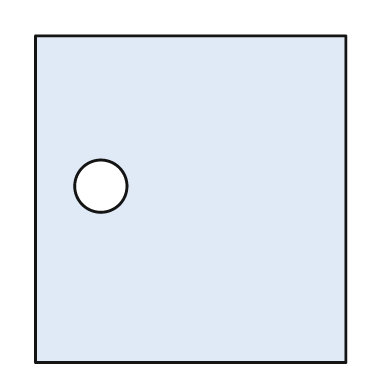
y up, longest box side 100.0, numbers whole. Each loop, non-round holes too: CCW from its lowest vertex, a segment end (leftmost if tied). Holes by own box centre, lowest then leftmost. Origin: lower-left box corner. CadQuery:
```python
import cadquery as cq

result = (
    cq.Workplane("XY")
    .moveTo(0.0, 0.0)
    .lineTo(95.0, 0.0)
    .lineTo(95.0, 100.0)
    .lineTo(0.0, 100.0)
    .close()
    .moveTo(20.0, 54.0)
    .circle(8.0)
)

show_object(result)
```